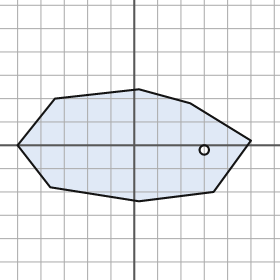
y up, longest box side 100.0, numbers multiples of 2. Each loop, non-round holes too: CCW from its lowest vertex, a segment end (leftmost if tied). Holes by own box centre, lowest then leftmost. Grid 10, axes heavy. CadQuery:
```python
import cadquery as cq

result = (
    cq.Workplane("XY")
    .moveTo(2.0, -24.0)
    .lineTo(34.0, -20.0)
    .lineTo(50.0, 2.0)
    .lineTo(24.0, 18.0)
    .lineTo(2.0, 24.0)
    .lineTo(-34.0, 20.0)
    .lineTo(-50.0, 0.0)
    .lineTo(-36.0, -18.0)
    .close()
    .moveTo(30.0, -2.0)
    .circle(2.0)
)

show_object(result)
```